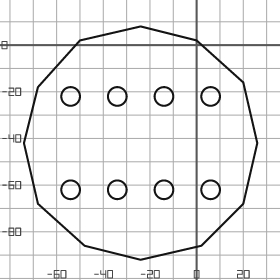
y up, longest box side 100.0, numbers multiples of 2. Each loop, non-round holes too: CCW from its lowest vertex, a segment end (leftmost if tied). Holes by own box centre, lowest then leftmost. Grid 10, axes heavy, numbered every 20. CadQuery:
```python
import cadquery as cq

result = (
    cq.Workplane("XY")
    .moveTo(-24.0, -92.0)
    .lineTo(2.0, -86.0)
    .lineTo(20.0, -68.0)
    .lineTo(26.0, -42.0)
    .lineTo(20.0, -16.0)
    .lineTo(0.0, 2.0)
    .lineTo(-24.0, 8.0)
    .lineTo(-50.0, 2.0)
    .lineTo(-68.0, -18.0)
    .lineTo(-74.0, -42.0)
    .lineTo(-68.0, -68.0)
    .lineTo(-48.0, -86.0)
    .close()
    .moveTo(-54.0, -62.0)
    .circle(4.0)
    .moveTo(-34.0, -62.0)
    .circle(4.0)
    .moveTo(-14.0, -62.0)
    .circle(4.0)
    .moveTo(6.0, -62.0)
    .circle(4.0)
    .moveTo(-54.0, -22.0)
    .circle(4.0)
    .moveTo(-34.0, -22.0)
    .circle(4.0)
    .moveTo(-14.0, -22.0)
    .circle(4.0)
    .moveTo(6.0, -22.0)
    .circle(4.0)
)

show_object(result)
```